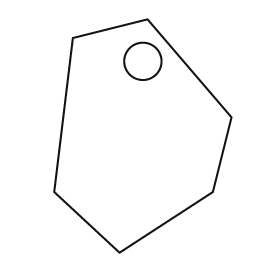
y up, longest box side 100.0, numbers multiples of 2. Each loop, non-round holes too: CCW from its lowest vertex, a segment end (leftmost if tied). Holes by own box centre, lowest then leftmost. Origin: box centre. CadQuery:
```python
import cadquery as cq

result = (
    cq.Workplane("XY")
    .moveTo(-10.0, -50.0)
    .lineTo(30.0, -24.0)
    .lineTo(38.0, 8.0)
    .lineTo(2.0, 50.0)
    .lineTo(-30.0, 42.0)
    .lineTo(-38.0, -24.0)
    .close()
    .moveTo(0.0, 32.0)
    .circle(8.0)
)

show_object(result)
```